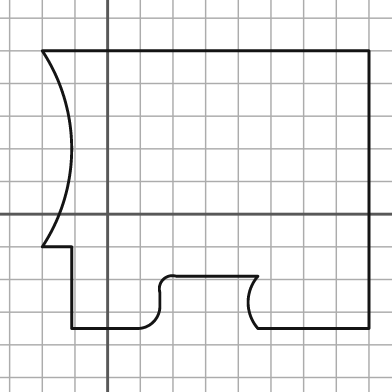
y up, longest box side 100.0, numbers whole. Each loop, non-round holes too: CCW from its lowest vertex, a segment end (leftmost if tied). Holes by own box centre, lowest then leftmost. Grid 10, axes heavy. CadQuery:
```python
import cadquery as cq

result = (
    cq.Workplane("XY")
    .moveTo(-11.0, -35.0)
    .lineTo(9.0, -35.0)
    .threePointArc((14.0, -33.0), (16.0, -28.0))
    .lineTo(16.0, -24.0)
    .threePointArc((17.0, -20.0), (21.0, -19.0))
    .lineTo(46.0, -19.0)
    .threePointArc((43.0, -27.0), (46.0, -35.0))
    .lineTo(80.0, -35.0)
    .lineTo(80.0, 50.0)
    .lineTo(-20.0, 50.0)
    .threePointArc((-11.0, 20.0), (-20.0, -10.0))
    .lineTo(-11.0, -10.0)
    .close()
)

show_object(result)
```